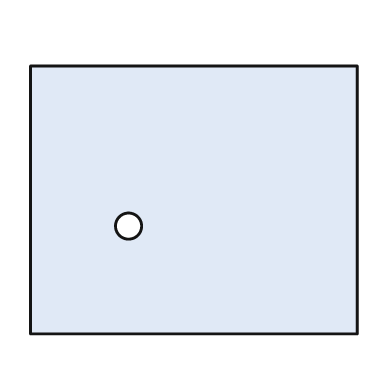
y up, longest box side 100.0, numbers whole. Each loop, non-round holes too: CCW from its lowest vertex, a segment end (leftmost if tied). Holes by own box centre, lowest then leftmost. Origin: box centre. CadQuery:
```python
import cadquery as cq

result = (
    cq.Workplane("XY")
    .moveTo(-50.0, -41.0)
    .lineTo(50.0, -41.0)
    .lineTo(50.0, 41.0)
    .lineTo(-50.0, 41.0)
    .close()
    .moveTo(-20.0, -8.0)
    .circle(4.0)
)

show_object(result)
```